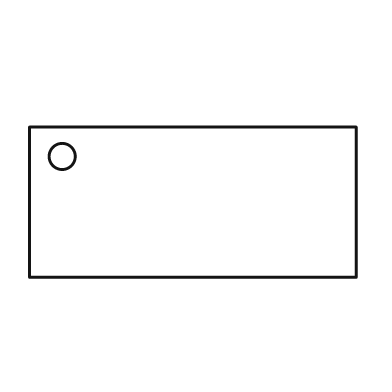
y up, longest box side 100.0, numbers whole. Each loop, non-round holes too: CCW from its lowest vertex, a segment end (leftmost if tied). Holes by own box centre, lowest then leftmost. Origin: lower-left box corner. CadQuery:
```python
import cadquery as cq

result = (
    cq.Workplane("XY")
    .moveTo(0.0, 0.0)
    .lineTo(100.0, 0.0)
    .lineTo(100.0, 46.0)
    .lineTo(0.0, 46.0)
    .close()
    .moveTo(10.0, 37.0)
    .circle(4.0)
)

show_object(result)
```